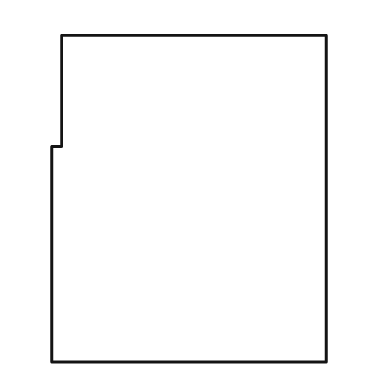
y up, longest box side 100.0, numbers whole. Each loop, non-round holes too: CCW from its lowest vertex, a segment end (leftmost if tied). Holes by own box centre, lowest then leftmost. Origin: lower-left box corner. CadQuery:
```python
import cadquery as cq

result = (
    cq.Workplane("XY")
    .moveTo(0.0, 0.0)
    .lineTo(84.0, 0.0)
    .lineTo(84.0, 100.0)
    .lineTo(3.0, 100.0)
    .lineTo(3.0, 66.0)
    .lineTo(0.0, 66.0)
    .close()
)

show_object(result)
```